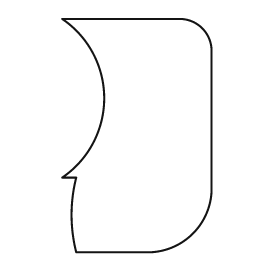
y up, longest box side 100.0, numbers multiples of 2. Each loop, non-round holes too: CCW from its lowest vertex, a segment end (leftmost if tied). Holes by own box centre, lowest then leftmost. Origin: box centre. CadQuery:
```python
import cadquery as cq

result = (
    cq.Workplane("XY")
    .moveTo(-26.0, -50.0)
    .lineTo(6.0, -50.0)
    .threePointArc((24.0, -42.0), (32.0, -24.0))
    .lineTo(32.0, 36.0)
    .threePointArc((28.0, 46.0), (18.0, 50.0))
    .lineTo(-32.0, 50.0)
    .threePointArc((-14.0, 16.0), (-32.0, -18.0))
    .lineTo(-26.0, -18.0)
    .threePointArc((-28.0, -34.0), (-26.0, -50.0))
    .close()
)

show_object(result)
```